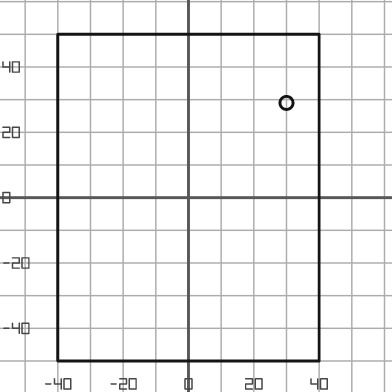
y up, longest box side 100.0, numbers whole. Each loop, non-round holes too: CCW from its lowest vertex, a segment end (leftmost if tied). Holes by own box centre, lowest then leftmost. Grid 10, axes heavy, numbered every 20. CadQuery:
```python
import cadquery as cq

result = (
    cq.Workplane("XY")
    .moveTo(-40.0, -50.0)
    .lineTo(40.0, -50.0)
    .lineTo(40.0, 50.0)
    .lineTo(-40.0, 50.0)
    .close()
    .moveTo(30.0, 29.0)
    .circle(2.0)
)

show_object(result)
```